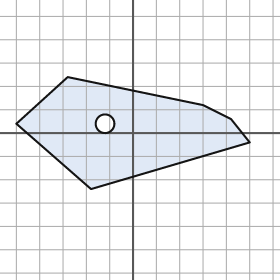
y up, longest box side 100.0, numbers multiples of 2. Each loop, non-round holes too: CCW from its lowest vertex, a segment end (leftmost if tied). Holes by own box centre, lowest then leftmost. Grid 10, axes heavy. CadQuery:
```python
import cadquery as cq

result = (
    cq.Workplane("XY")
    .moveTo(-18.0, -24.0)
    .lineTo(50.0, -4.0)
    .lineTo(42.0, 6.0)
    .lineTo(30.0, 12.0)
    .lineTo(-28.0, 24.0)
    .lineTo(-50.0, 4.0)
    .close()
    .moveTo(-12.0, 4.0)
    .circle(4.0)
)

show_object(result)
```